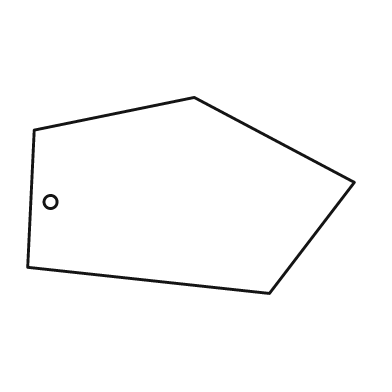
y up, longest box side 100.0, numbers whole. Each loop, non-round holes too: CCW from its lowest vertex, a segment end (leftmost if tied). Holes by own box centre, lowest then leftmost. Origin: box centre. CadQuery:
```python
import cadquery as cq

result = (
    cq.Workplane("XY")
    .moveTo(24.0, -30.0)
    .lineTo(50.0, 4.0)
    .lineTo(1.0, 30.0)
    .lineTo(-48.0, 20.0)
    .lineTo(-50.0, -22.0)
    .close()
    .moveTo(-43.0, -2.0)
    .circle(2.0)
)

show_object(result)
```